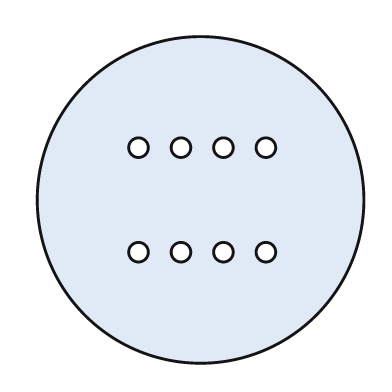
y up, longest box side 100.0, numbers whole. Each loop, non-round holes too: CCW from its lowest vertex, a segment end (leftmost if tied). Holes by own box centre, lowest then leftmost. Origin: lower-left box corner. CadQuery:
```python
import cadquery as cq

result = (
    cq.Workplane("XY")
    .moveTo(50.0, 50.0)
    .circle(50.0)
    .moveTo(31.0, 34.0)
    .circle(3.0)
    .moveTo(44.0, 34.0)
    .circle(3.0)
    .moveTo(57.0, 34.0)
    .circle(3.0)
    .moveTo(70.0, 34.0)
    .circle(3.0)
    .moveTo(31.0, 66.0)
    .circle(3.0)
    .moveTo(44.0, 66.0)
    .circle(3.0)
    .moveTo(57.0, 66.0)
    .circle(3.0)
    .moveTo(70.0, 66.0)
    .circle(3.0)
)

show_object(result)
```